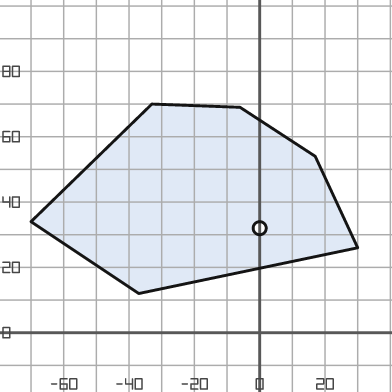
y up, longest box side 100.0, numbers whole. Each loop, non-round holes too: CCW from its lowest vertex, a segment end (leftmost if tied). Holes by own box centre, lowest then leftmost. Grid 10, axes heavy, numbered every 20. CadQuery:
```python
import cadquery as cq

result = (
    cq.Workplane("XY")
    .moveTo(-37.0, 12.0)
    .lineTo(30.0, 26.0)
    .lineTo(17.0, 54.0)
    .lineTo(-6.0, 69.0)
    .lineTo(-33.0, 70.0)
    .lineTo(-70.0, 34.0)
    .close()
    .moveTo(0.0, 32.0)
    .circle(2.0)
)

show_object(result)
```